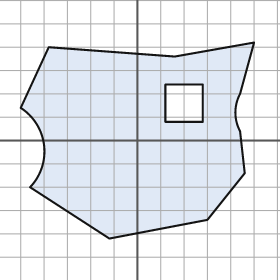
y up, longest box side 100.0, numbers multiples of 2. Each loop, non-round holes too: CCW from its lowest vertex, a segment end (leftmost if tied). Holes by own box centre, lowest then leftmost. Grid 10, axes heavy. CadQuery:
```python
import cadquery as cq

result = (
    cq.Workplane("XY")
    .moveTo(-12.0, -42.0)
    .lineTo(30.0, -34.0)
    .lineTo(46.0, -14.0)
    .lineTo(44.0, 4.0)
    .threePointArc((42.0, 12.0), (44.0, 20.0))
    .lineTo(50.0, 42.0)
    .lineTo(16.0, 36.0)
    .lineTo(-38.0, 40.0)
    .lineTo(-50.0, 14.0)
    .threePointArc((-40.0, -2.0), (-46.0, -20.0))
    .close()
    .moveTo(12.0, 8.0)
    .lineTo(28.0, 8.0)
    .lineTo(28.0, 24.0)
    .lineTo(12.0, 24.0)
    .close()
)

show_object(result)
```